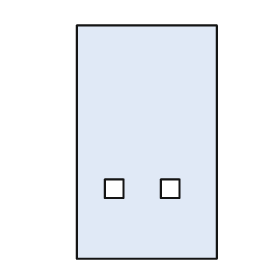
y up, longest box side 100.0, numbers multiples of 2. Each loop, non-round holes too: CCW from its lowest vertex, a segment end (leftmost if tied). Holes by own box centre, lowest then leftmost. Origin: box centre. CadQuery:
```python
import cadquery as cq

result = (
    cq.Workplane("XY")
    .moveTo(-30.0, -50.0)
    .lineTo(30.0, -50.0)
    .lineTo(30.0, 50.0)
    .lineTo(-30.0, 50.0)
    .close()
    .moveTo(-18.0, -24.0)
    .lineTo(-10.0, -24.0)
    .lineTo(-10.0, -16.0)
    .lineTo(-18.0, -16.0)
    .close()
    .moveTo(6.0, -24.0)
    .lineTo(14.0, -24.0)
    .lineTo(14.0, -16.0)
    .lineTo(6.0, -16.0)
    .close()
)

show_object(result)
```